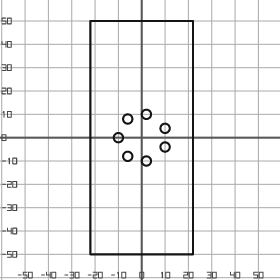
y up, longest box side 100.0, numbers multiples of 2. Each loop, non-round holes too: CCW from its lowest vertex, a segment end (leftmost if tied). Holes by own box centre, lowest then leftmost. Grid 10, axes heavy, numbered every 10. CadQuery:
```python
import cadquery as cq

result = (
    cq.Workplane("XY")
    .moveTo(-22.0, -50.0)
    .lineTo(22.0, -50.0)
    .lineTo(22.0, 50.0)
    .lineTo(-22.0, 50.0)
    .close()
    .moveTo(2.0, -10.0)
    .circle(2.0)
    .moveTo(-6.0, -8.0)
    .circle(2.0)
    .moveTo(10.0, -4.0)
    .circle(2.0)
    .moveTo(-10.0, 0.0)
    .circle(2.0)
    .moveTo(10.0, 4.0)
    .circle(2.0)
    .moveTo(-6.0, 8.0)
    .circle(2.0)
    .moveTo(2.0, 10.0)
    .circle(2.0)
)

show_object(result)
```